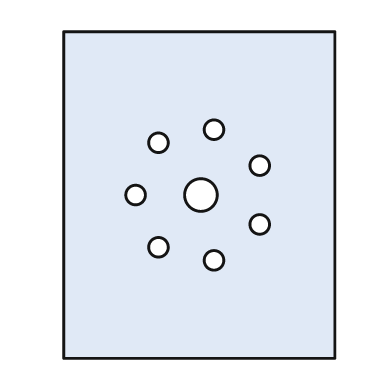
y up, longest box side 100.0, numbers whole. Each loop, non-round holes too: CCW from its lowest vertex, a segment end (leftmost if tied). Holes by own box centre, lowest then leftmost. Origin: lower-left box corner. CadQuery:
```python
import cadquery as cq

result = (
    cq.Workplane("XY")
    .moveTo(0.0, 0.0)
    .lineTo(83.0, 0.0)
    .lineTo(83.0, 100.0)
    .lineTo(0.0, 100.0)
    .close()
    .moveTo(46.0, 30.0)
    .circle(3.0)
    .moveTo(29.0, 34.0)
    .circle(3.0)
    .moveTo(60.0, 41.0)
    .circle(3.0)
    .moveTo(22.0, 50.0)
    .circle(3.0)
    .moveTo(42.0, 50.0)
    .circle(5.0)
    .moveTo(60.0, 59.0)
    .circle(3.0)
    .moveTo(29.0, 66.0)
    .circle(3.0)
    .moveTo(46.0, 70.0)
    .circle(3.0)
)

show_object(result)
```